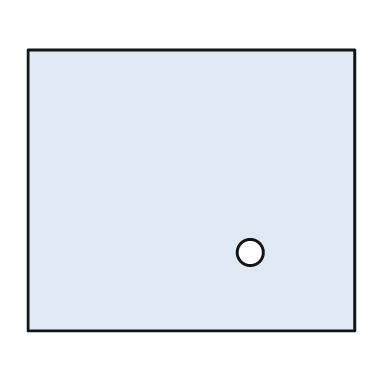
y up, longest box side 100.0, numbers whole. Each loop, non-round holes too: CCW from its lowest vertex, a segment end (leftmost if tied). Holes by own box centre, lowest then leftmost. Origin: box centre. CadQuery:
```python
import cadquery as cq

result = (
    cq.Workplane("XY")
    .moveTo(-50.0, -43.0)
    .lineTo(50.0, -43.0)
    .lineTo(50.0, 43.0)
    .lineTo(-50.0, 43.0)
    .close()
    .moveTo(18.0, -19.0)
    .circle(4.0)
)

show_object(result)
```